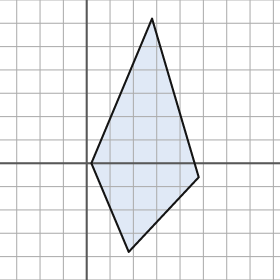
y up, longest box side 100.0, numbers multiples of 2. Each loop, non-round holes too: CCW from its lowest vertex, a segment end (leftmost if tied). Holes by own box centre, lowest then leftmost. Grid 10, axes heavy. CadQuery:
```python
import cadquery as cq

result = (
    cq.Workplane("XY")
    .moveTo(18.0, -38.0)
    .lineTo(48.0, -6.0)
    .lineTo(28.0, 62.0)
    .lineTo(2.0, 0.0)
    .close()
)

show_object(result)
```